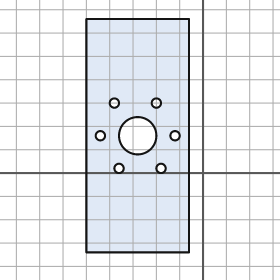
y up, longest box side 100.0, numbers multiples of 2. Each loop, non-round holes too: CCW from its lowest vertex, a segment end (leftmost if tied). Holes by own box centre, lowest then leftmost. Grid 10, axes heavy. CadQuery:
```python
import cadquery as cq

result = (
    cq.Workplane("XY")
    .moveTo(-50.0, -34.0)
    .lineTo(-6.0, -34.0)
    .lineTo(-6.0, 66.0)
    .lineTo(-50.0, 66.0)
    .close()
    .moveTo(-36.0, 2.0)
    .circle(2.0)
    .moveTo(-18.0, 2.0)
    .circle(2.0)
    .moveTo(-44.0, 16.0)
    .circle(2.0)
    .moveTo(-28.0, 16.0)
    .circle(8.0)
    .moveTo(-12.0, 16.0)
    .circle(2.0)
    .moveTo(-38.0, 30.0)
    .circle(2.0)
    .moveTo(-20.0, 30.0)
    .circle(2.0)
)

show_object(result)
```